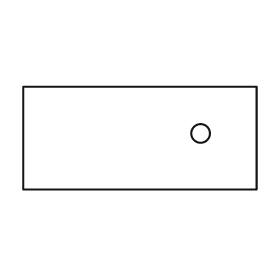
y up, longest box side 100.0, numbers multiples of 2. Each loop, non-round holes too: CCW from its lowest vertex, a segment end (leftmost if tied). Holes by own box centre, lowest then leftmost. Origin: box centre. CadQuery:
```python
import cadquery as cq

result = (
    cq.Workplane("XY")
    .moveTo(-50.0, -22.0)
    .lineTo(50.0, -22.0)
    .lineTo(50.0, 22.0)
    .lineTo(-50.0, 22.0)
    .close()
    .moveTo(26.0, 2.0)
    .circle(4.0)
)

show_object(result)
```